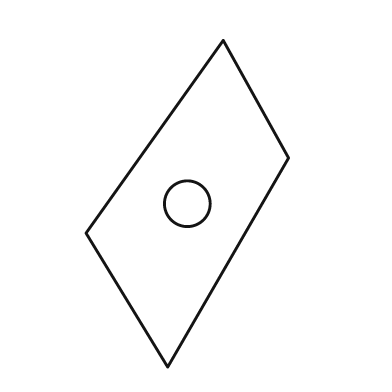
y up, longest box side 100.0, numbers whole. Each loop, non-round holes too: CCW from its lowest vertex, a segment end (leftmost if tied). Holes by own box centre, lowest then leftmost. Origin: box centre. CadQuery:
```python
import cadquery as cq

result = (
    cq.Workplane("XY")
    .moveTo(-6.0, -50.0)
    .lineTo(31.0, 14.0)
    .lineTo(11.0, 50.0)
    .lineTo(-31.0, -9.0)
    .close()
    .moveTo(0.0, 0.0)
    .circle(7.0)
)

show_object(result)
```